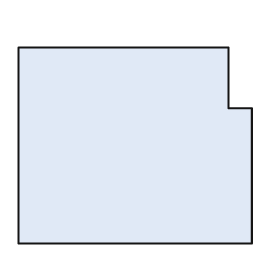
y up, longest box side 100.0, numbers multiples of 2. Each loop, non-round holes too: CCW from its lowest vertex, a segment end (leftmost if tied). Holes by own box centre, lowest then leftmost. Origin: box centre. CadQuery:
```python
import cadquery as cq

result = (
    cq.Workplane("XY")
    .moveTo(-50.0, -42.0)
    .lineTo(50.0, -42.0)
    .lineTo(50.0, 16.0)
    .lineTo(40.0, 16.0)
    .lineTo(40.0, 42.0)
    .lineTo(-50.0, 42.0)
    .close()
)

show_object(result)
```